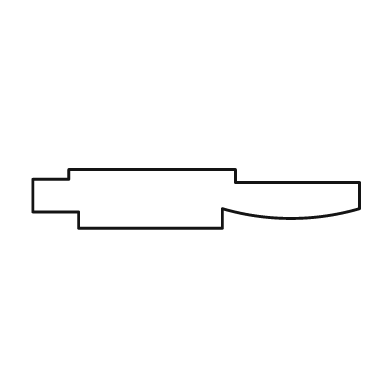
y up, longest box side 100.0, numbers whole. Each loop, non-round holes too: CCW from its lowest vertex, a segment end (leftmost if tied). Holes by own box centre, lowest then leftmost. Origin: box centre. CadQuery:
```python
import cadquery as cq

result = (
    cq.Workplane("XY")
    .moveTo(-36.0, -9.0)
    .lineTo(8.0, -9.0)
    .lineTo(8.0, -3.0)
    .threePointArc((29.0, -6.0), (50.0, -3.0))
    .lineTo(50.0, 5.0)
    .lineTo(12.0, 5.0)
    .lineTo(12.0, 9.0)
    .lineTo(-39.0, 9.0)
    .lineTo(-39.0, 6.0)
    .lineTo(-50.0, 6.0)
    .lineTo(-50.0, -4.0)
    .lineTo(-36.0, -4.0)
    .close()
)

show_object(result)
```